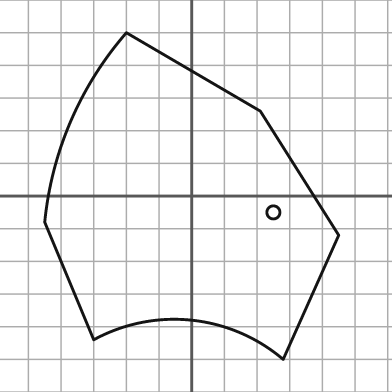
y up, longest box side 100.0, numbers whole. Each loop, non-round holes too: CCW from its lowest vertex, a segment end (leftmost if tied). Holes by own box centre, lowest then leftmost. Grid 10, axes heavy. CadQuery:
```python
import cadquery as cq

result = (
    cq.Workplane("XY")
    .moveTo(28.0, -50.0)
    .lineTo(45.0, -12.0)
    .lineTo(21.0, 26.0)
    .lineTo(-20.0, 50.0)
    .threePointArc((-37.0, 23.0), (-45.0, -8.0))
    .lineTo(-30.0, -44.0)
    .threePointArc((0.0, -38.0), (28.0, -50.0))
    .close()
    .moveTo(25.0, -5.0)
    .circle(2.0)
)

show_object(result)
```